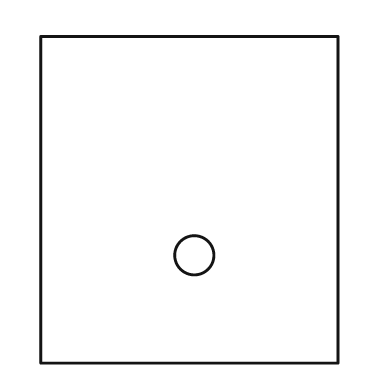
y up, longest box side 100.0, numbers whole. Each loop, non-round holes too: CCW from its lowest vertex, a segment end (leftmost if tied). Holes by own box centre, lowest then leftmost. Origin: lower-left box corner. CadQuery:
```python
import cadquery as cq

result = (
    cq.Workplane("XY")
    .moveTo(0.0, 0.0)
    .lineTo(91.0, 0.0)
    .lineTo(91.0, 100.0)
    .lineTo(0.0, 100.0)
    .close()
    .moveTo(47.0, 33.0)
    .circle(6.0)
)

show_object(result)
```